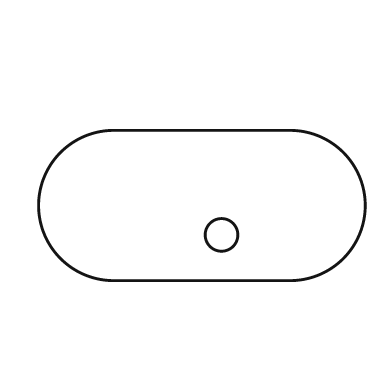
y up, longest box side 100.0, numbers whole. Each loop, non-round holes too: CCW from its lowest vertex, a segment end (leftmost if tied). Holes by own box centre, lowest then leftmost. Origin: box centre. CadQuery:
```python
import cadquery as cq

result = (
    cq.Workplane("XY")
    .moveTo(-27.0, -23.0)
    .lineTo(27.0, -23.0)
    .threePointArc((50.0, 0.0), (27.0, 23.0))
    .lineTo(-27.0, 23.0)
    .threePointArc((-50.0, 0.0), (-27.0, -23.0))
    .close()
    .moveTo(6.0, -9.0)
    .circle(5.0)
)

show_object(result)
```